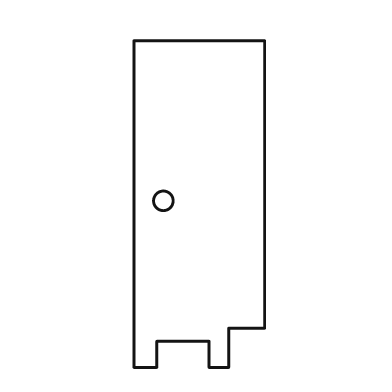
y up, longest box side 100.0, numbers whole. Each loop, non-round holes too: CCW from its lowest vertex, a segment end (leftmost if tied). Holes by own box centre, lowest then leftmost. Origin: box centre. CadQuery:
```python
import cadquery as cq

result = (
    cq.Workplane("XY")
    .moveTo(-20.0, -50.0)
    .lineTo(-13.0, -50.0)
    .lineTo(-13.0, -42.0)
    .lineTo(3.0, -42.0)
    .lineTo(3.0, -50.0)
    .lineTo(9.0, -50.0)
    .lineTo(9.0, -38.0)
    .lineTo(20.0, -38.0)
    .lineTo(20.0, 50.0)
    .lineTo(-20.0, 50.0)
    .close()
    .moveTo(-11.0, 1.0)
    .circle(3.0)
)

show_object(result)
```